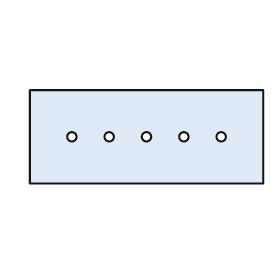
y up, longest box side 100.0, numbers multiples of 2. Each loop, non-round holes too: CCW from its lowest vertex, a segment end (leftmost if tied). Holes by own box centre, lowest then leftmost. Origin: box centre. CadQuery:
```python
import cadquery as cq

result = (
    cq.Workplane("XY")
    .moveTo(-50.0, -20.0)
    .lineTo(50.0, -20.0)
    .lineTo(50.0, 20.0)
    .lineTo(-50.0, 20.0)
    .close()
    .moveTo(-32.0, 0.0)
    .circle(2.0)
    .moveTo(-16.0, 0.0)
    .circle(2.0)
    .moveTo(0.0, 0.0)
    .circle(2.0)
    .moveTo(16.0, 0.0)
    .circle(2.0)
    .moveTo(32.0, 0.0)
    .circle(2.0)
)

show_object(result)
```